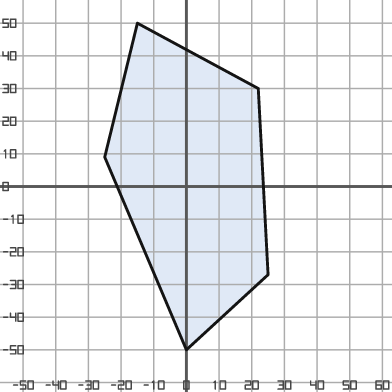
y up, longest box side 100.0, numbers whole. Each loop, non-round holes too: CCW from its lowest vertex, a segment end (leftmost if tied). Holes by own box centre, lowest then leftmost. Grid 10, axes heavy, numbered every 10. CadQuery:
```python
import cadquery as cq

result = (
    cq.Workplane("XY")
    .moveTo(0.0, -50.0)
    .lineTo(25.0, -27.0)
    .lineTo(22.0, 30.0)
    .lineTo(-15.0, 50.0)
    .lineTo(-25.0, 9.0)
    .close()
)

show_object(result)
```